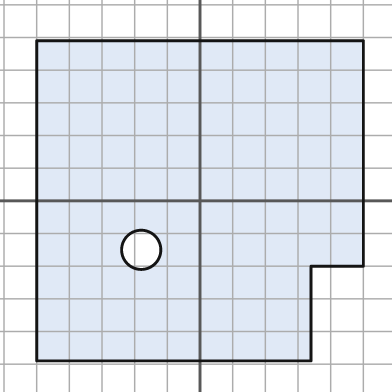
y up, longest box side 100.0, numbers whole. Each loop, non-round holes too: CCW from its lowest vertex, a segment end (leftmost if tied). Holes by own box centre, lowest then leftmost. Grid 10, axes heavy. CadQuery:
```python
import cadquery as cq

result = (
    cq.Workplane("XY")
    .moveTo(-50.0, -49.0)
    .lineTo(34.0, -49.0)
    .lineTo(34.0, -20.0)
    .lineTo(50.0, -20.0)
    .lineTo(50.0, 49.0)
    .lineTo(-50.0, 49.0)
    .close()
    .moveTo(-18.0, -15.0)
    .circle(6.0)
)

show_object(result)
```